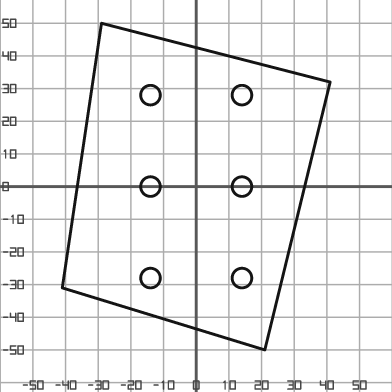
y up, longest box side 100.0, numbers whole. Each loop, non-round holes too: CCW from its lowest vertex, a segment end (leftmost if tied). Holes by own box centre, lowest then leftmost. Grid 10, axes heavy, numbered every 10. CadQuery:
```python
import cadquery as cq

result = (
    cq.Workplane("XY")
    .moveTo(21.0, -50.0)
    .lineTo(41.0, 32.0)
    .lineTo(-29.0, 50.0)
    .lineTo(-41.0, -31.0)
    .close()
    .moveTo(-14.0, -28.0)
    .circle(3.0)
    .moveTo(14.0, -28.0)
    .circle(3.0)
    .moveTo(-14.0, 0.0)
    .circle(3.0)
    .moveTo(14.0, 0.0)
    .circle(3.0)
    .moveTo(-14.0, 28.0)
    .circle(3.0)
    .moveTo(14.0, 28.0)
    .circle(3.0)
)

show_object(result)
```